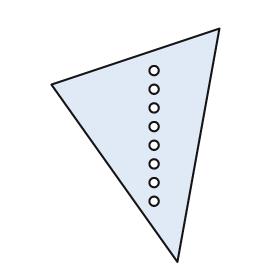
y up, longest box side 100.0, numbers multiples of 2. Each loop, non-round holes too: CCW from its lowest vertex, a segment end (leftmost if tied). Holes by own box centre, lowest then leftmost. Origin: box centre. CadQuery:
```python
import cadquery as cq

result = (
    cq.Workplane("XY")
    .moveTo(18.0, -50.0)
    .lineTo(36.0, 50.0)
    .lineTo(-36.0, 26.0)
    .close()
    .moveTo(8.0, -24.0)
    .circle(2.0)
    .moveTo(8.0, -16.0)
    .circle(2.0)
    .moveTo(8.0, -8.0)
    .circle(2.0)
    .moveTo(8.0, 0.0)
    .circle(2.0)
    .moveTo(8.0, 8.0)
    .circle(2.0)
    .moveTo(8.0, 16.0)
    .circle(2.0)
    .moveTo(8.0, 24.0)
    .circle(2.0)
    .moveTo(8.0, 32.0)
    .circle(2.0)
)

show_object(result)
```